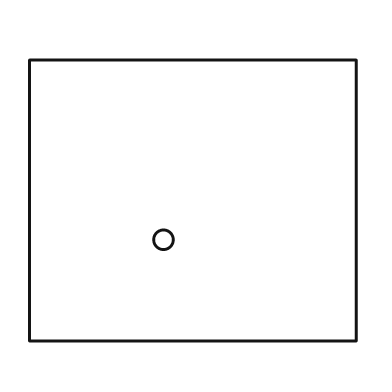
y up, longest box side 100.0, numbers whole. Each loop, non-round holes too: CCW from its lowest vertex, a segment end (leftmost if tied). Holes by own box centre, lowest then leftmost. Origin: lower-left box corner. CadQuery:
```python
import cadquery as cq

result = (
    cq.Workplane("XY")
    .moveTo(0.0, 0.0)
    .lineTo(100.0, 0.0)
    .lineTo(100.0, 86.0)
    .lineTo(0.0, 86.0)
    .close()
    .moveTo(41.0, 31.0)
    .circle(3.0)
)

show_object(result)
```